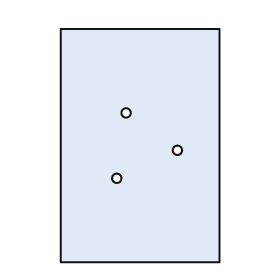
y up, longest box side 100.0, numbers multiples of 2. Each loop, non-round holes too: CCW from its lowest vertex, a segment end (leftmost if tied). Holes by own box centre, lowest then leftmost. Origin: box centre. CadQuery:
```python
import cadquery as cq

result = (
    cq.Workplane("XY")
    .moveTo(-34.0, -50.0)
    .lineTo(34.0, -50.0)
    .lineTo(34.0, 50.0)
    .lineTo(-34.0, 50.0)
    .close()
    .moveTo(-10.0, -14.0)
    .circle(2.0)
    .moveTo(16.0, -2.0)
    .circle(2.0)
    .moveTo(-6.0, 14.0)
    .circle(2.0)
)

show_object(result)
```